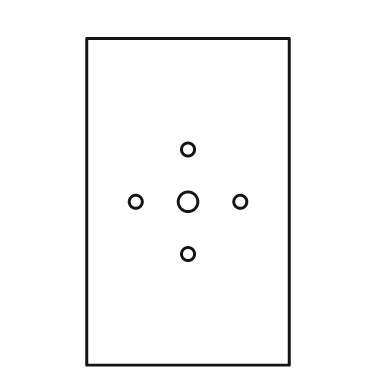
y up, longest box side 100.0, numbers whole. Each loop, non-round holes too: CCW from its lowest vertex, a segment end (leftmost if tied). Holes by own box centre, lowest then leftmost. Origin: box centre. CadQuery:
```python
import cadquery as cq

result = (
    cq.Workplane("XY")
    .moveTo(-31.0, -50.0)
    .lineTo(31.0, -50.0)
    .lineTo(31.0, 50.0)
    .lineTo(-31.0, 50.0)
    .close()
    .moveTo(0.0, -16.0)
    .circle(2.0)
    .moveTo(-16.0, 0.0)
    .circle(2.0)
    .moveTo(0.0, 0.0)
    .circle(3.0)
    .moveTo(16.0, 0.0)
    .circle(2.0)
    .moveTo(0.0, 16.0)
    .circle(2.0)
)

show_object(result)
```